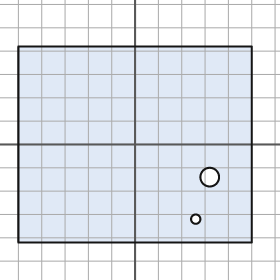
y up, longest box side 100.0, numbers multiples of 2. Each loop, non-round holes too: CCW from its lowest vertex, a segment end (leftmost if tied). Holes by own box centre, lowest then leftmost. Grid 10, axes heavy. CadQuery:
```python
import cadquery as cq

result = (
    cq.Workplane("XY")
    .moveTo(-50.0, -42.0)
    .lineTo(50.0, -42.0)
    .lineTo(50.0, 42.0)
    .lineTo(-50.0, 42.0)
    .close()
    .moveTo(26.0, -32.0)
    .circle(2.0)
    .moveTo(32.0, -14.0)
    .circle(4.0)
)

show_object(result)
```